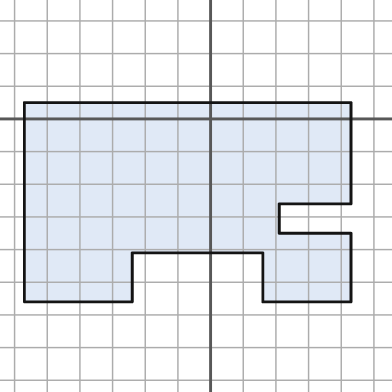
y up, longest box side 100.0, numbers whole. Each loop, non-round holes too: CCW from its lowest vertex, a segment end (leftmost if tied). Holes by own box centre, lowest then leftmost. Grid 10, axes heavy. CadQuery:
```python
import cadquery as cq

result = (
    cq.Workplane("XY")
    .moveTo(-57.0, -56.0)
    .lineTo(-24.0, -56.0)
    .lineTo(-24.0, -41.0)
    .lineTo(16.0, -41.0)
    .lineTo(16.0, -56.0)
    .lineTo(43.0, -56.0)
    .lineTo(43.0, -35.0)
    .lineTo(21.0, -35.0)
    .lineTo(21.0, -26.0)
    .lineTo(43.0, -26.0)
    .lineTo(43.0, 5.0)
    .lineTo(-57.0, 5.0)
    .close()
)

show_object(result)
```